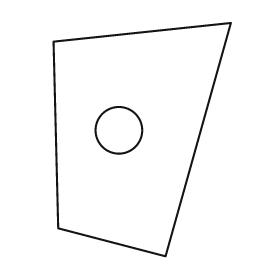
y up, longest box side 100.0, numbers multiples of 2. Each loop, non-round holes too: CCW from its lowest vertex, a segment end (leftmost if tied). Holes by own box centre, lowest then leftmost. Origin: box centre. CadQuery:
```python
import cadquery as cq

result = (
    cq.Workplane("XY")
    .moveTo(10.0, -50.0)
    .lineTo(38.0, 50.0)
    .lineTo(-38.0, 42.0)
    .lineTo(-36.0, -38.0)
    .close()
    .moveTo(-10.0, 4.0)
    .circle(10.0)
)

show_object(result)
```